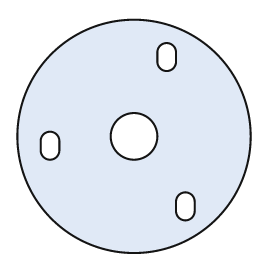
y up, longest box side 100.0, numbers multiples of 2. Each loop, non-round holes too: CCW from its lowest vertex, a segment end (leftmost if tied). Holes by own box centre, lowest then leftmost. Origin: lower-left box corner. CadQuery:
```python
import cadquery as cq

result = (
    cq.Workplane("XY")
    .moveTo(50.0, 50.0)
    .circle(50.0)
    .moveTo(68.0, 18.0)
    .threePointArc((72.0, 14.0), (76.0, 18.0))
    .lineTo(76.0, 22.0)
    .threePointArc((72.0, 26.0), (68.0, 22.0))
    .close()
    .moveTo(10.0, 44.0)
    .threePointArc((14.0, 40.0), (18.0, 44.0))
    .lineTo(18.0, 48.0)
    .threePointArc((14.0, 52.0), (10.0, 48.0))
    .close()
    .moveTo(50.0, 50.0)
    .circle(10.0)
    .moveTo(60.0, 82.0)
    .threePointArc((64.0, 78.0), (68.0, 82.0))
    .lineTo(68.0, 86.0)
    .threePointArc((64.0, 90.0), (60.0, 86.0))
    .close()
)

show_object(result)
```